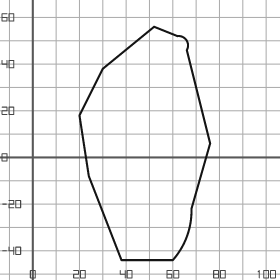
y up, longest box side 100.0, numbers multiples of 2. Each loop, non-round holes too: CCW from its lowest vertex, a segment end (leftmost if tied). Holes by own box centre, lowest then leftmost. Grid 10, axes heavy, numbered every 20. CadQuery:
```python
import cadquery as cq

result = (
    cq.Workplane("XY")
    .moveTo(38.0, -44.0)
    .lineTo(60.0, -44.0)
    .threePointArc((66.0, -34.0), (68.0, -22.0))
    .lineTo(76.0, 6.0)
    .lineTo(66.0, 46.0)
    .threePointArc((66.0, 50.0), (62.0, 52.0))
    .lineTo(52.0, 56.0)
    .lineTo(30.0, 38.0)
    .lineTo(20.0, 18.0)
    .lineTo(24.0, -8.0)
    .close()
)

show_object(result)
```